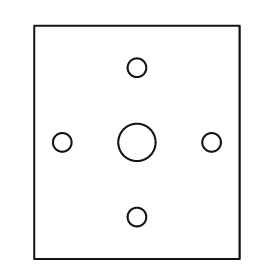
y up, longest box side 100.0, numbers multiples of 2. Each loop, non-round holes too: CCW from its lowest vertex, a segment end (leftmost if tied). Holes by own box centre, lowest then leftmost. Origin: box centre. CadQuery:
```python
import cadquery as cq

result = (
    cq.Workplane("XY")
    .moveTo(-44.0, -50.0)
    .lineTo(44.0, -50.0)
    .lineTo(44.0, 50.0)
    .lineTo(-44.0, 50.0)
    .close()
    .moveTo(0.0, -32.0)
    .circle(4.0)
    .moveTo(-32.0, 0.0)
    .circle(4.0)
    .moveTo(0.0, 0.0)
    .circle(8.0)
    .moveTo(32.0, 0.0)
    .circle(4.0)
    .moveTo(0.0, 32.0)
    .circle(4.0)
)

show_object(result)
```